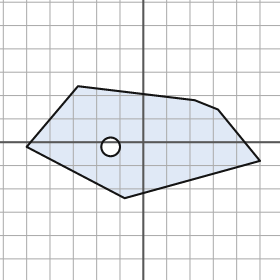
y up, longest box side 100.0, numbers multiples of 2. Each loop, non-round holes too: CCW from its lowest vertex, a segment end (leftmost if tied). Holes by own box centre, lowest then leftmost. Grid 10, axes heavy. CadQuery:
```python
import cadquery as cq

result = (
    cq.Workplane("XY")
    .moveTo(-8.0, -24.0)
    .lineTo(50.0, -8.0)
    .lineTo(32.0, 14.0)
    .lineTo(22.0, 18.0)
    .lineTo(-28.0, 24.0)
    .lineTo(-50.0, -2.0)
    .close()
    .moveTo(-14.0, -2.0)
    .circle(4.0)
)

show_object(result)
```